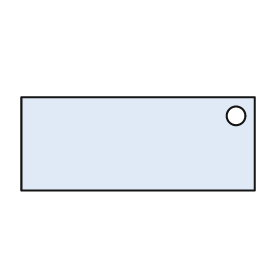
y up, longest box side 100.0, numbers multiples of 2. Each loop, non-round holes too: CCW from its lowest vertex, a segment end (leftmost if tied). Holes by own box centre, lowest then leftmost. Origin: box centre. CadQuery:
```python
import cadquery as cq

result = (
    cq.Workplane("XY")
    .moveTo(-50.0, -20.0)
    .lineTo(50.0, -20.0)
    .lineTo(50.0, 20.0)
    .lineTo(-50.0, 20.0)
    .close()
    .moveTo(42.0, 12.0)
    .circle(4.0)
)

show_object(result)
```